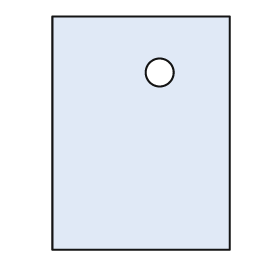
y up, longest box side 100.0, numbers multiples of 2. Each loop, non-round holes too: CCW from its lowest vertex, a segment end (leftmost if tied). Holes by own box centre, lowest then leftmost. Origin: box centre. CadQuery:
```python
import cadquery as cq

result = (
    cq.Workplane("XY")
    .moveTo(-38.0, -50.0)
    .lineTo(38.0, -50.0)
    .lineTo(38.0, 50.0)
    .lineTo(-38.0, 50.0)
    .close()
    .moveTo(8.0, 26.0)
    .circle(6.0)
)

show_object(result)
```